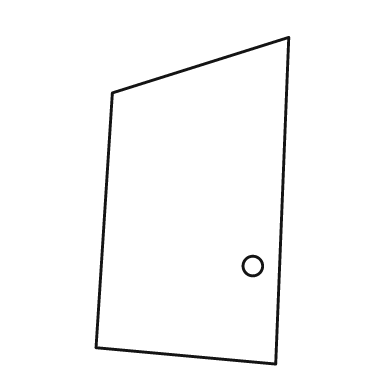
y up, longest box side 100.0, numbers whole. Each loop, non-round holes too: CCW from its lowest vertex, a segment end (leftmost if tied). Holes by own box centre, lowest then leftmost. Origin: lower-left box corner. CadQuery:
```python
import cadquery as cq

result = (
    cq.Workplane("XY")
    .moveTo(55.0, 0.0)
    .lineTo(59.0, 100.0)
    .lineTo(5.0, 83.0)
    .lineTo(0.0, 5.0)
    .close()
    .moveTo(48.0, 30.0)
    .circle(3.0)
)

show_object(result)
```